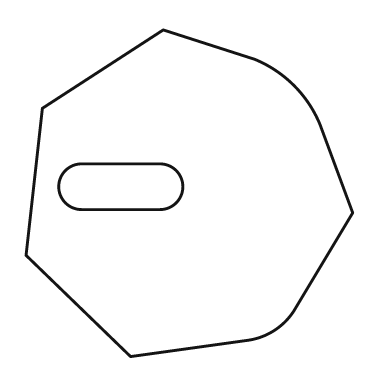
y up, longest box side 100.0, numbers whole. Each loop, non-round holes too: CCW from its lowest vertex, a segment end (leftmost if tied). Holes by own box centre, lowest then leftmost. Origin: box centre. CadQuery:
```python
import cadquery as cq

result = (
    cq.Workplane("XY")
    .moveTo(-18.0, -50.0)
    .lineTo(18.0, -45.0)
    .threePointArc((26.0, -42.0), (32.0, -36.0))
    .lineTo(50.0, -6.0)
    .lineTo(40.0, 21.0)
    .threePointArc((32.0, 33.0), (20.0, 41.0))
    .lineTo(-8.0, 50.0)
    .lineTo(-45.0, 26.0)
    .lineTo(-50.0, -19.0)
    .close()
    .moveTo(-33.0, -5.0)
    .lineTo(-9.0, -5.0)
    .threePointArc((-2.0, 2.0), (-9.0, 9.0))
    .lineTo(-33.0, 9.0)
    .threePointArc((-40.0, 2.0), (-33.0, -5.0))
    .close()
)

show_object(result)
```